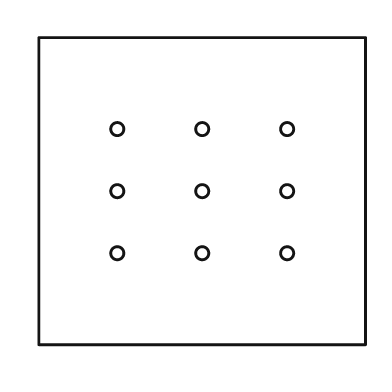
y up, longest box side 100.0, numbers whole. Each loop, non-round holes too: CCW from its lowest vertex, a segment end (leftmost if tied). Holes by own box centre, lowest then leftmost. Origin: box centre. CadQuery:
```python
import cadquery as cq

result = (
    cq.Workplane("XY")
    .moveTo(-50.0, -47.0)
    .lineTo(50.0, -47.0)
    .lineTo(50.0, 47.0)
    .lineTo(-50.0, 47.0)
    .close()
    .moveTo(-26.0, -19.0)
    .circle(2.0)
    .moveTo(0.0, -19.0)
    .circle(2.0)
    .moveTo(26.0, -19.0)
    .circle(2.0)
    .moveTo(-26.0, 0.0)
    .circle(2.0)
    .moveTo(0.0, 0.0)
    .circle(2.0)
    .moveTo(26.0, 0.0)
    .circle(2.0)
    .moveTo(-26.0, 19.0)
    .circle(2.0)
    .moveTo(0.0, 19.0)
    .circle(2.0)
    .moveTo(26.0, 19.0)
    .circle(2.0)
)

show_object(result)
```